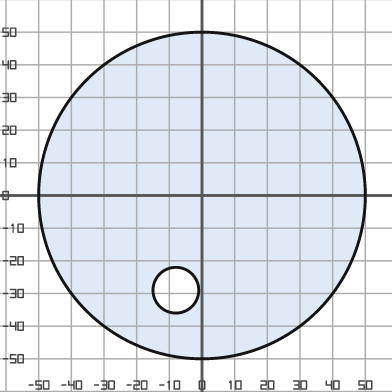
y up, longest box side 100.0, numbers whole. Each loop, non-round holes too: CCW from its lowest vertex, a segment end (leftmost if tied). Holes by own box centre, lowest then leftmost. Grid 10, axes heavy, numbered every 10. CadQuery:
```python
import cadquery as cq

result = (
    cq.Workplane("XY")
    .moveTo(0.0, 0.0)
    .circle(50.0)
    .moveTo(-8.0, -29.0)
    .circle(7.0)
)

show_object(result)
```